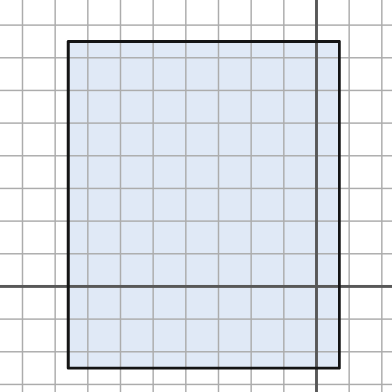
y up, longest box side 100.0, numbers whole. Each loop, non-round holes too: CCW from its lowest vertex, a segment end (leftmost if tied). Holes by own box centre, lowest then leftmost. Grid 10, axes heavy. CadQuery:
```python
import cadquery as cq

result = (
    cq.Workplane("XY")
    .moveTo(-76.0, -25.0)
    .lineTo(7.0, -25.0)
    .lineTo(7.0, 75.0)
    .lineTo(-76.0, 75.0)
    .close()
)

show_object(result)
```